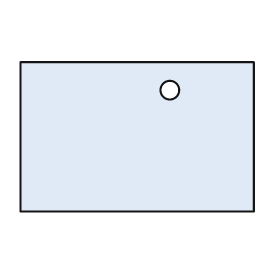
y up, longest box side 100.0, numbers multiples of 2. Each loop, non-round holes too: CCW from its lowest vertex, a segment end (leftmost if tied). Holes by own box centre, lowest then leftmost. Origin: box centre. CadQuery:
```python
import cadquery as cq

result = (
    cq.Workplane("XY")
    .moveTo(-50.0, -32.0)
    .lineTo(50.0, -32.0)
    .lineTo(50.0, 32.0)
    .lineTo(-50.0, 32.0)
    .close()
    .moveTo(14.0, 20.0)
    .circle(4.0)
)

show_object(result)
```